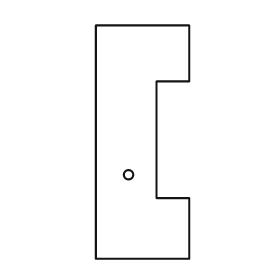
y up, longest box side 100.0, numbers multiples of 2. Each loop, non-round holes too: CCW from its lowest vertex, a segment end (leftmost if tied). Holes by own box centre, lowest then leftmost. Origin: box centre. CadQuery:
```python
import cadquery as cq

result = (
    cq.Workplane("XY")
    .moveTo(-20.0, -50.0)
    .lineTo(20.0, -50.0)
    .lineTo(20.0, -24.0)
    .lineTo(6.0, -24.0)
    .lineTo(6.0, 26.0)
    .lineTo(20.0, 26.0)
    .lineTo(20.0, 50.0)
    .lineTo(-20.0, 50.0)
    .close()
    .moveTo(-6.0, -14.0)
    .circle(2.0)
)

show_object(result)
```